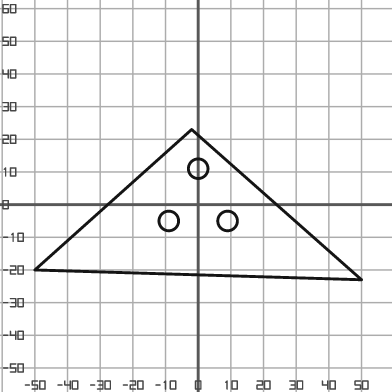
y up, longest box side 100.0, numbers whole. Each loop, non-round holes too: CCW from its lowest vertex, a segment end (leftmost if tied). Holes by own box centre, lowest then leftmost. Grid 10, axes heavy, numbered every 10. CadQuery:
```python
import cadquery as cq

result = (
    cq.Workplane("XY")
    .moveTo(50.0, -23.0)
    .lineTo(-2.0, 23.0)
    .lineTo(-50.0, -20.0)
    .close()
    .moveTo(-9.0, -5.0)
    .circle(3.0)
    .moveTo(9.0, -5.0)
    .circle(3.0)
    .moveTo(0.0, 11.0)
    .circle(3.0)
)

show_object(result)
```